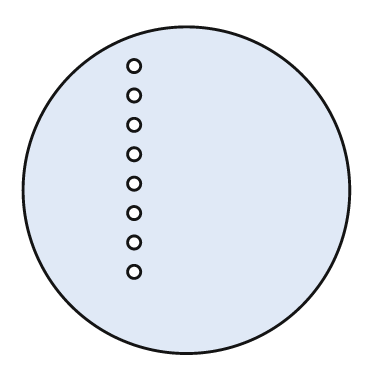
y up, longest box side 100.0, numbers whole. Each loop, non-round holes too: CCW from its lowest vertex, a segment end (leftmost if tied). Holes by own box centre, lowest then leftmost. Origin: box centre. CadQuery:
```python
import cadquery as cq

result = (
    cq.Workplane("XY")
    .moveTo(0.0, 0.0)
    .circle(50.0)
    .moveTo(-16.0, -25.0)
    .circle(2.0)
    .moveTo(-16.0, -16.0)
    .circle(2.0)
    .moveTo(-16.0, -7.0)
    .circle(2.0)
    .moveTo(-16.0, 2.0)
    .circle(2.0)
    .moveTo(-16.0, 11.0)
    .circle(2.0)
    .moveTo(-16.0, 20.0)
    .circle(2.0)
    .moveTo(-16.0, 29.0)
    .circle(2.0)
    .moveTo(-16.0, 38.0)
    .circle(2.0)
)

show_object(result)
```